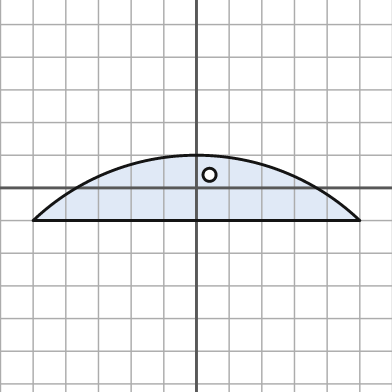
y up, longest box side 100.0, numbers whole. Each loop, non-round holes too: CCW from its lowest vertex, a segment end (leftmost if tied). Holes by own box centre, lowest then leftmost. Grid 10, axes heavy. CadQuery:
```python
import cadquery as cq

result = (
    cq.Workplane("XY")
    .moveTo(-50.0, -10.0)
    .lineTo(50.0, -10.0)
    .threePointArc((0.0, 10.0), (-50.0, -10.0))
    .close()
    .moveTo(4.0, 4.0)
    .circle(2.0)
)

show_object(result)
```